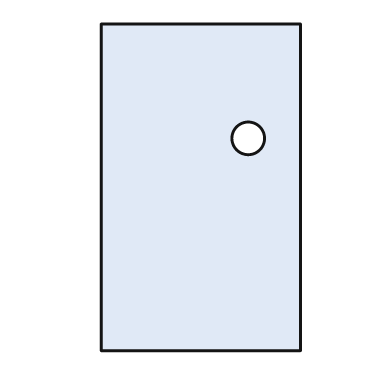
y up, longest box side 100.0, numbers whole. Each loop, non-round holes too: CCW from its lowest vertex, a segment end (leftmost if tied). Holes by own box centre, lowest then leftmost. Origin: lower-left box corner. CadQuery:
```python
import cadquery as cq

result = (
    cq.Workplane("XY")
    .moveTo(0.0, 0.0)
    .lineTo(61.0, 0.0)
    .lineTo(61.0, 100.0)
    .lineTo(0.0, 100.0)
    .close()
    .moveTo(45.0, 65.0)
    .circle(5.0)
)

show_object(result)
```